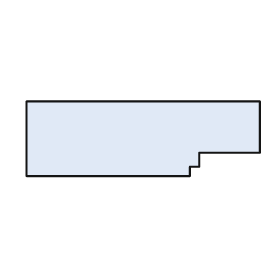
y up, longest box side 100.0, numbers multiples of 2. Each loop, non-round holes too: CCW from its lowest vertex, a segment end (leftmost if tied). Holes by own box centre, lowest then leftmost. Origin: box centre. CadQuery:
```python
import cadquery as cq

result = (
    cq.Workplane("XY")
    .moveTo(-50.0, -16.0)
    .lineTo(20.0, -16.0)
    .lineTo(20.0, -12.0)
    .lineTo(24.0, -12.0)
    .lineTo(24.0, -6.0)
    .lineTo(50.0, -6.0)
    .lineTo(50.0, 16.0)
    .lineTo(-50.0, 16.0)
    .close()
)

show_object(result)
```